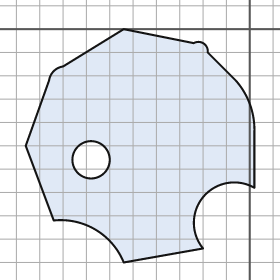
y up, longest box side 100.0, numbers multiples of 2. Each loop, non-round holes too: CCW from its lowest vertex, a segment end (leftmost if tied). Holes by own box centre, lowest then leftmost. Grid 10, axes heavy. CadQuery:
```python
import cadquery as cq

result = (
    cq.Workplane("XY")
    .moveTo(-54.0, -100.0)
    .lineTo(-20.0, -94.0)
    .threePointArc((-20.0, -72.0), (2.0, -68.0))
    .lineTo(2.0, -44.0)
    .threePointArc((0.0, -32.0), (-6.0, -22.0))
    .lineTo(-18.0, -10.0)
    .threePointArc((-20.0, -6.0), (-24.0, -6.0))
    .lineTo(-54.0, 0.0)
    .lineTo(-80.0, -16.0)
    .threePointArc((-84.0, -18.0), (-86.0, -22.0))
    .lineTo(-96.0, -50.0)
    .lineTo(-84.0, -82.0)
    .threePointArc((-66.0, -86.0), (-54.0, -100.0))
    .close()
    .moveTo(-68.0, -56.0)
    .circle(8.0)
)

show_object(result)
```